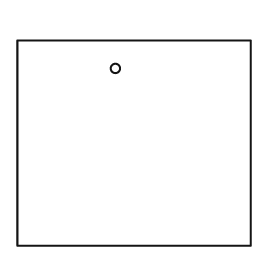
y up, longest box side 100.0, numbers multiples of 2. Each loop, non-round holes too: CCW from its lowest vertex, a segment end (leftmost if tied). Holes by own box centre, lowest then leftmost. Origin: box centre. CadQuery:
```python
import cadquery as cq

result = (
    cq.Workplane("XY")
    .moveTo(-50.0, -44.0)
    .lineTo(50.0, -44.0)
    .lineTo(50.0, 44.0)
    .lineTo(-50.0, 44.0)
    .close()
    .moveTo(-8.0, 32.0)
    .circle(2.0)
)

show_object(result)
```